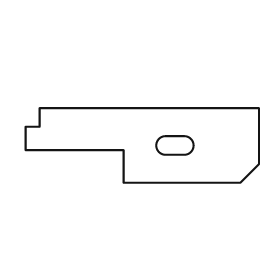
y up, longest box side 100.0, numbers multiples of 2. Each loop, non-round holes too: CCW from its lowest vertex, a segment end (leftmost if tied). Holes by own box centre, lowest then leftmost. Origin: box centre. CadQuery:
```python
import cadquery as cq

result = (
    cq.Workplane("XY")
    .moveTo(-8.0, -16.0)
    .lineTo(42.0, -16.0)
    .lineTo(50.0, -8.0)
    .lineTo(50.0, 16.0)
    .lineTo(-44.0, 16.0)
    .lineTo(-44.0, 8.0)
    .lineTo(-50.0, 8.0)
    .lineTo(-50.0, -2.0)
    .lineTo(-8.0, -2.0)
    .close()
    .moveTo(10.0, -4.0)
    .lineTo(18.0, -4.0)
    .threePointArc((22.0, 0.0), (18.0, 4.0))
    .lineTo(10.0, 4.0)
    .threePointArc((6.0, 0.0), (10.0, -4.0))
    .close()
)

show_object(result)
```